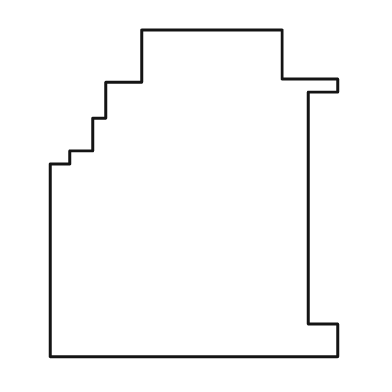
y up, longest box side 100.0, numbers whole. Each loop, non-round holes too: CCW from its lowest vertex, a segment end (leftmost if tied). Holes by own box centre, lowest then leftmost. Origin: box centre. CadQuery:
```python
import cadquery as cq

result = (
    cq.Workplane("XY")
    .moveTo(-44.0, -50.0)
    .lineTo(44.0, -50.0)
    .lineTo(44.0, -40.0)
    .lineTo(35.0, -40.0)
    .lineTo(35.0, 31.0)
    .lineTo(44.0, 31.0)
    .lineTo(44.0, 35.0)
    .lineTo(27.0, 35.0)
    .lineTo(27.0, 50.0)
    .lineTo(-16.0, 50.0)
    .lineTo(-16.0, 34.0)
    .lineTo(-27.0, 34.0)
    .lineTo(-27.0, 23.0)
    .lineTo(-31.0, 23.0)
    .lineTo(-31.0, 13.0)
    .lineTo(-38.0, 13.0)
    .lineTo(-38.0, 9.0)
    .lineTo(-44.0, 9.0)
    .close()
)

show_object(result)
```